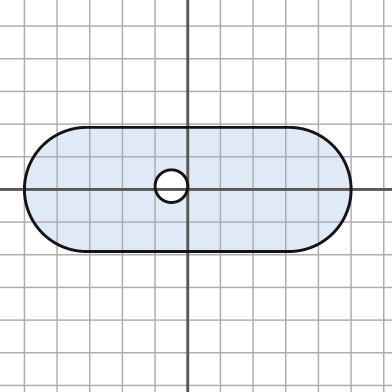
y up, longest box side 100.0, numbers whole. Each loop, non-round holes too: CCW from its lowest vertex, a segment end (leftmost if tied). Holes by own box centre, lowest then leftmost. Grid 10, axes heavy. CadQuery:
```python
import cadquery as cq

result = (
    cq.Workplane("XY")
    .moveTo(-31.0, -19.0)
    .lineTo(31.0, -19.0)
    .threePointArc((50.0, 0.0), (31.0, 19.0))
    .lineTo(-31.0, 19.0)
    .threePointArc((-50.0, 0.0), (-31.0, -19.0))
    .close()
    .moveTo(-5.0, 1.0)
    .circle(5.0)
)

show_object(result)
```